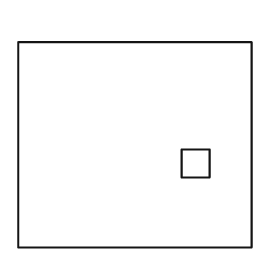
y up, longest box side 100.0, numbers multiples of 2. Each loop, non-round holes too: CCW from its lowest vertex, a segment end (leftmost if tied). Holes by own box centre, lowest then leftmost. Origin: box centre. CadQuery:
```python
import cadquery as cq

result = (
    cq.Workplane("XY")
    .moveTo(-50.0, -44.0)
    .lineTo(50.0, -44.0)
    .lineTo(50.0, 44.0)
    .lineTo(-50.0, 44.0)
    .close()
    .moveTo(20.0, -14.0)
    .lineTo(32.0, -14.0)
    .lineTo(32.0, -2.0)
    .lineTo(20.0, -2.0)
    .close()
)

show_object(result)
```